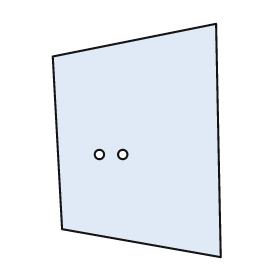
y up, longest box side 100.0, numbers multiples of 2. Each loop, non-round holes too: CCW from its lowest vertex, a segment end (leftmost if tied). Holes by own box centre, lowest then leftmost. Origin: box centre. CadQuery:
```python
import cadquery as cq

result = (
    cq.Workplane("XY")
    .moveTo(36.0, -50.0)
    .lineTo(34.0, 50.0)
    .lineTo(-36.0, 36.0)
    .lineTo(-32.0, -38.0)
    .close()
    .moveTo(-16.0, -6.0)
    .circle(2.0)
    .moveTo(-6.0, -6.0)
    .circle(2.0)
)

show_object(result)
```